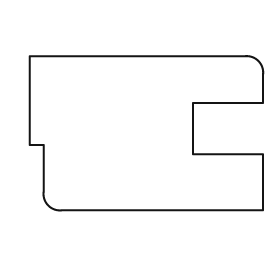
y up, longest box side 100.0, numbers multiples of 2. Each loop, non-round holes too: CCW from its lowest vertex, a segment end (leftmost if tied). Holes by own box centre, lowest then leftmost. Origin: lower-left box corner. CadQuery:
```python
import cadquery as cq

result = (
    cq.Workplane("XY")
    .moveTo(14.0, 0.0)
    .lineTo(100.0, 0.0)
    .lineTo(100.0, 24.0)
    .lineTo(70.0, 24.0)
    .lineTo(70.0, 46.0)
    .lineTo(100.0, 46.0)
    .lineTo(100.0, 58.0)
    .threePointArc((98.0, 64.0), (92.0, 66.0))
    .lineTo(0.0, 66.0)
    .lineTo(0.0, 28.0)
    .lineTo(6.0, 28.0)
    .lineTo(6.0, 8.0)
    .threePointArc((8.0, 2.0), (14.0, 0.0))
    .close()
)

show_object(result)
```